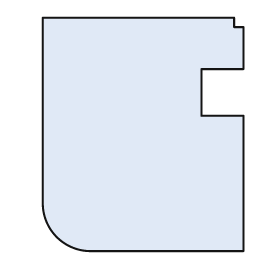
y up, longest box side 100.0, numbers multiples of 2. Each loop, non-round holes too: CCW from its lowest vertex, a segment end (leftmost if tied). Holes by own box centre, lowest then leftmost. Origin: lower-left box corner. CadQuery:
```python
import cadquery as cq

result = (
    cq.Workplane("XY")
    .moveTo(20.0, 0.0)
    .lineTo(86.0, 0.0)
    .lineTo(86.0, 58.0)
    .lineTo(68.0, 58.0)
    .lineTo(68.0, 78.0)
    .lineTo(86.0, 78.0)
    .lineTo(86.0, 96.0)
    .lineTo(82.0, 96.0)
    .lineTo(82.0, 100.0)
    .lineTo(0.0, 100.0)
    .lineTo(0.0, 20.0)
    .threePointArc((6.0, 6.0), (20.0, 0.0))
    .close()
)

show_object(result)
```